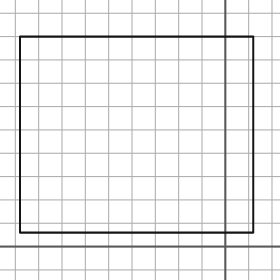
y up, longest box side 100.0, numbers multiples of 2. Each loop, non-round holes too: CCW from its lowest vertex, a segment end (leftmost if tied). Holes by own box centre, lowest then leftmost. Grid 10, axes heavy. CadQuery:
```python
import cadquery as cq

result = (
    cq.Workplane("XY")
    .moveTo(-88.0, 6.0)
    .lineTo(12.0, 6.0)
    .lineTo(12.0, 90.0)
    .lineTo(-88.0, 90.0)
    .close()
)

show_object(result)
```